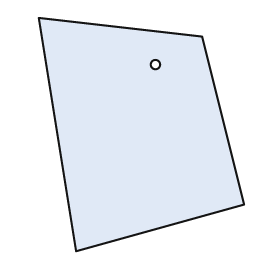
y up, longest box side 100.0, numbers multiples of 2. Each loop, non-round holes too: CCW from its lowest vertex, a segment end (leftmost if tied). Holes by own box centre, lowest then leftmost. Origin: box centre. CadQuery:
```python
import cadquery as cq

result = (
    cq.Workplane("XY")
    .moveTo(-28.0, -50.0)
    .lineTo(44.0, -30.0)
    .lineTo(26.0, 42.0)
    .lineTo(-44.0, 50.0)
    .close()
    .moveTo(6.0, 30.0)
    .circle(2.0)
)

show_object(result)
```